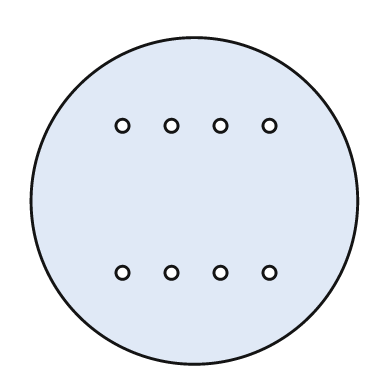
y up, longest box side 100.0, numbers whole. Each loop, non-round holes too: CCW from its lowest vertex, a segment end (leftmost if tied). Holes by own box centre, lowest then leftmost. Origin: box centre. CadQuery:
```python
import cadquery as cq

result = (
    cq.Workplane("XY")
    .moveTo(0.0, 0.0)
    .circle(50.0)
    .moveTo(-22.0, -22.0)
    .circle(2.0)
    .moveTo(-7.0, -22.0)
    .circle(2.0)
    .moveTo(8.0, -22.0)
    .circle(2.0)
    .moveTo(23.0, -22.0)
    .circle(2.0)
    .moveTo(-22.0, 23.0)
    .circle(2.0)
    .moveTo(-7.0, 23.0)
    .circle(2.0)
    .moveTo(8.0, 23.0)
    .circle(2.0)
    .moveTo(23.0, 23.0)
    .circle(2.0)
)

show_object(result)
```